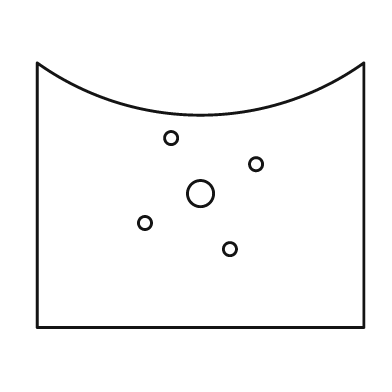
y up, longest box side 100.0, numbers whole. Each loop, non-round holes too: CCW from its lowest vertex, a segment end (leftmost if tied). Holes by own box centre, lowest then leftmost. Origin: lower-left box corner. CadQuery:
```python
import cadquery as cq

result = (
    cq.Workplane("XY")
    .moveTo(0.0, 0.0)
    .lineTo(100.0, 0.0)
    .lineTo(100.0, 81.0)
    .threePointArc((50.0, 65.0), (0.0, 81.0))
    .close()
    .moveTo(59.0, 24.0)
    .circle(2.0)
    .moveTo(33.0, 32.0)
    .circle(2.0)
    .moveTo(50.0, 41.0)
    .circle(4.0)
    .moveTo(67.0, 50.0)
    .circle(2.0)
    .moveTo(41.0, 58.0)
    .circle(2.0)
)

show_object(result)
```